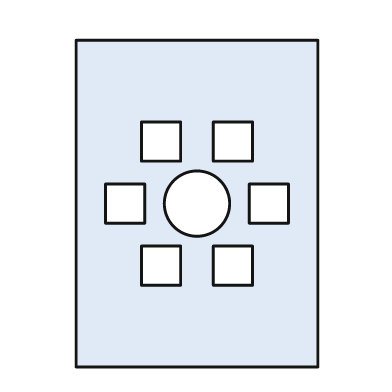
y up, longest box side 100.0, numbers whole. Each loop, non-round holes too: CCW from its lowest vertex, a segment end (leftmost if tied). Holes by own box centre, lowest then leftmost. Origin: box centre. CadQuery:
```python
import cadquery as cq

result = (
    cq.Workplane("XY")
    .moveTo(-37.0, -50.0)
    .lineTo(37.0, -50.0)
    .lineTo(37.0, 50.0)
    .lineTo(-37.0, 50.0)
    .close()
    .moveTo(-17.0, -25.0)
    .lineTo(-5.0, -25.0)
    .lineTo(-5.0, -13.0)
    .lineTo(-17.0, -13.0)
    .close()
    .moveTo(5.0, -25.0)
    .lineTo(17.0, -25.0)
    .lineTo(17.0, -13.0)
    .lineTo(5.0, -13.0)
    .close()
    .moveTo(-28.0, -6.0)
    .lineTo(-16.0, -6.0)
    .lineTo(-16.0, 6.0)
    .lineTo(-28.0, 6.0)
    .close()
    .moveTo(0.0, 0.0)
    .circle(10.0)
    .moveTo(16.0, -6.0)
    .lineTo(28.0, -6.0)
    .lineTo(28.0, 6.0)
    .lineTo(16.0, 6.0)
    .close()
    .moveTo(-17.0, 13.0)
    .lineTo(-5.0, 13.0)
    .lineTo(-5.0, 25.0)
    .lineTo(-17.0, 25.0)
    .close()
    .moveTo(5.0, 13.0)
    .lineTo(17.0, 13.0)
    .lineTo(17.0, 25.0)
    .lineTo(5.0, 25.0)
    .close()
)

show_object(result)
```